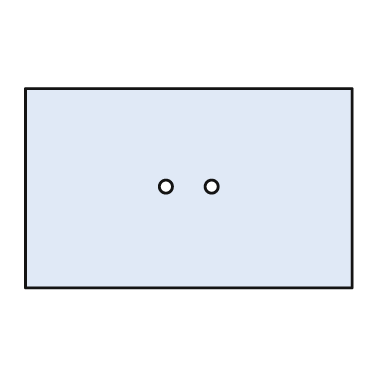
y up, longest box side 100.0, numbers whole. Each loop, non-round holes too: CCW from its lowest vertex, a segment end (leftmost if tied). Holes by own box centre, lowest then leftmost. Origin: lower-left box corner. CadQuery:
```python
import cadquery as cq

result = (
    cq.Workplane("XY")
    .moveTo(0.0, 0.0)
    .lineTo(100.0, 0.0)
    .lineTo(100.0, 61.0)
    .lineTo(0.0, 61.0)
    .close()
    .moveTo(43.0, 31.0)
    .circle(2.0)
    .moveTo(57.0, 31.0)
    .circle(2.0)
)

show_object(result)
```